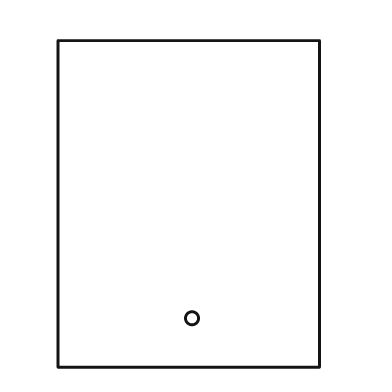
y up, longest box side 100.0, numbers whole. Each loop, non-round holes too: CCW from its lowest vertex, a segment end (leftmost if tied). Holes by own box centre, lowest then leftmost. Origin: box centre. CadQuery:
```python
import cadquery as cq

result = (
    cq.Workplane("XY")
    .moveTo(-40.0, -50.0)
    .lineTo(40.0, -50.0)
    .lineTo(40.0, 50.0)
    .lineTo(-40.0, 50.0)
    .close()
    .moveTo(1.0, -35.0)
    .circle(2.0)
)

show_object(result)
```